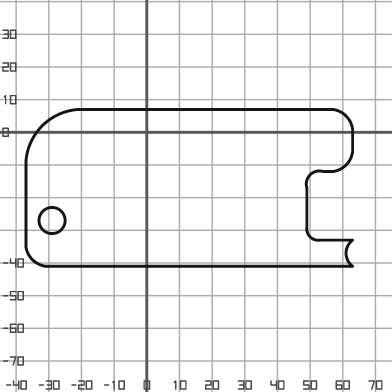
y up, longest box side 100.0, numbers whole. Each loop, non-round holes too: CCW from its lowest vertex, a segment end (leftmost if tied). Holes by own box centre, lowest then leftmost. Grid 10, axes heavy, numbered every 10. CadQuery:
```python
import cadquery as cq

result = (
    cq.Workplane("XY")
    .moveTo(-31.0, -41.0)
    .lineTo(63.0, -41.0)
    .threePointArc((61.0, -37.0), (63.0, -33.0))
    .lineTo(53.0, -33.0)
    .threePointArc((50.0, -32.0), (49.0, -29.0))
    .lineTo(49.0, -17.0)
    .threePointArc((50.0, -13.0), (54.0, -12.0))
    .lineTo(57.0, -12.0)
    .threePointArc((61.0, -10.0), (63.0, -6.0))
    .lineTo(63.0, 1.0)
    .threePointArc((61.0, 5.0), (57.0, 7.0))
    .lineTo(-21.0, 7.0)
    .threePointArc((-32.0, 2.0), (-37.0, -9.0))
    .lineTo(-37.0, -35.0)
    .threePointArc((-35.0, -39.0), (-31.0, -41.0))
    .close()
    .moveTo(-29.0, -27.0)
    .circle(4.0)
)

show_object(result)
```